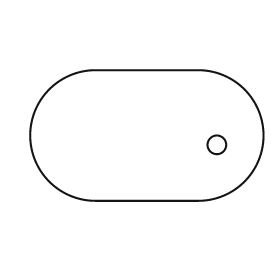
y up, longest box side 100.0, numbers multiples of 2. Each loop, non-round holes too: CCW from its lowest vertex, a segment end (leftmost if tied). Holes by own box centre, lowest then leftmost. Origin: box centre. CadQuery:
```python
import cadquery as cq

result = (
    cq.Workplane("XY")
    .moveTo(-22.0, -28.0)
    .lineTo(22.0, -28.0)
    .threePointArc((50.0, 0.0), (22.0, 28.0))
    .lineTo(-22.0, 28.0)
    .threePointArc((-50.0, 0.0), (-22.0, -28.0))
    .close()
    .moveTo(30.0, -4.0)
    .circle(4.0)
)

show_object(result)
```